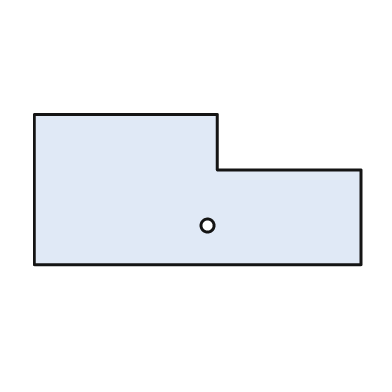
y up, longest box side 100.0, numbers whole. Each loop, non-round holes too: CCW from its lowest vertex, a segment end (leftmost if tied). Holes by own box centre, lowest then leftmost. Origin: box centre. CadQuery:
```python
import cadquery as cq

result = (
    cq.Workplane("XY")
    .moveTo(-50.0, -23.0)
    .lineTo(50.0, -23.0)
    .lineTo(50.0, 6.0)
    .lineTo(6.0, 6.0)
    .lineTo(6.0, 23.0)
    .lineTo(-50.0, 23.0)
    .close()
    .moveTo(3.0, -11.0)
    .circle(2.0)
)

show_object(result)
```